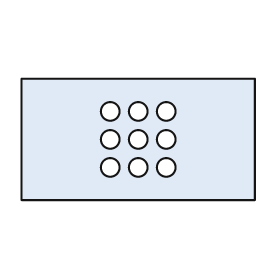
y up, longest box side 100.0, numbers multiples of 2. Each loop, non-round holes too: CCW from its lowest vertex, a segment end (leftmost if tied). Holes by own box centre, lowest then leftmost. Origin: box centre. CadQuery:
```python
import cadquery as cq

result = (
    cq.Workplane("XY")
    .moveTo(-50.0, -26.0)
    .lineTo(50.0, -26.0)
    .lineTo(50.0, 26.0)
    .lineTo(-50.0, 26.0)
    .close()
    .moveTo(-12.0, -12.0)
    .circle(4.0)
    .moveTo(0.0, -12.0)
    .circle(4.0)
    .moveTo(12.0, -12.0)
    .circle(4.0)
    .moveTo(-12.0, 0.0)
    .circle(4.0)
    .moveTo(0.0, 0.0)
    .circle(4.0)
    .moveTo(12.0, 0.0)
    .circle(4.0)
    .moveTo(-12.0, 12.0)
    .circle(4.0)
    .moveTo(0.0, 12.0)
    .circle(4.0)
    .moveTo(12.0, 12.0)
    .circle(4.0)
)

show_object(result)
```